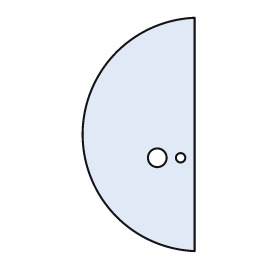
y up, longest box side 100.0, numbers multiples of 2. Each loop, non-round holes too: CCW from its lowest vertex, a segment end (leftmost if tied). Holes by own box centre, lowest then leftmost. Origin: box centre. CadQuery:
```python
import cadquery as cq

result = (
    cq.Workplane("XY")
    .moveTo(24.0, -50.0)
    .lineTo(24.0, 50.0)
    .threePointArc((-24.0, 0.0), (24.0, -50.0))
    .close()
    .moveTo(8.0, -10.0)
    .circle(4.0)
    .moveTo(18.0, -10.0)
    .circle(2.0)
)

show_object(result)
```